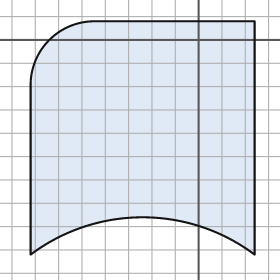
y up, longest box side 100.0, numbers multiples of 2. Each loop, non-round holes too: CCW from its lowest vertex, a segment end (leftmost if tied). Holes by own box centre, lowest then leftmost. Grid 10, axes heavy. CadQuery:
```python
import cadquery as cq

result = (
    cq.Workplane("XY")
    .moveTo(-72.0, -92.0)
    .threePointArc((-24.0, -76.0), (24.0, -92.0))
    .lineTo(24.0, 8.0)
    .lineTo(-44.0, 8.0)
    .threePointArc((-64.0, 0.0), (-72.0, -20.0))
    .close()
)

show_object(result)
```